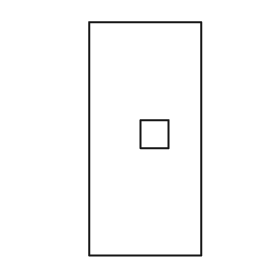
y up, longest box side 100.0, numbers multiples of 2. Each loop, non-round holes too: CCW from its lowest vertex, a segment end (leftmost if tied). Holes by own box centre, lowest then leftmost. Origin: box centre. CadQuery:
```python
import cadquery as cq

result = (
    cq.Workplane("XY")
    .moveTo(-24.0, -50.0)
    .lineTo(24.0, -50.0)
    .lineTo(24.0, 50.0)
    .lineTo(-24.0, 50.0)
    .close()
    .moveTo(-2.0, -4.0)
    .lineTo(10.0, -4.0)
    .lineTo(10.0, 8.0)
    .lineTo(-2.0, 8.0)
    .close()
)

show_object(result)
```